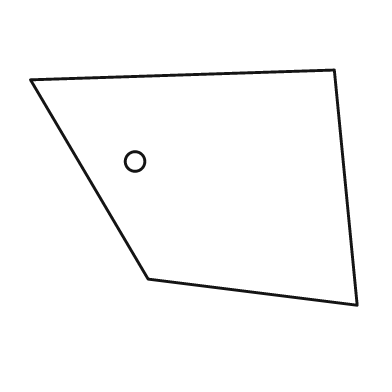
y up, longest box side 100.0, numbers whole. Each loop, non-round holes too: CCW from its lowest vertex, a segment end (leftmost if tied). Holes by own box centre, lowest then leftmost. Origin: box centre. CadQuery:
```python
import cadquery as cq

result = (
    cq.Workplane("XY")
    .moveTo(50.0, -36.0)
    .lineTo(43.0, 36.0)
    .lineTo(-50.0, 33.0)
    .lineTo(-14.0, -28.0)
    .close()
    .moveTo(-18.0, 8.0)
    .circle(3.0)
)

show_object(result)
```